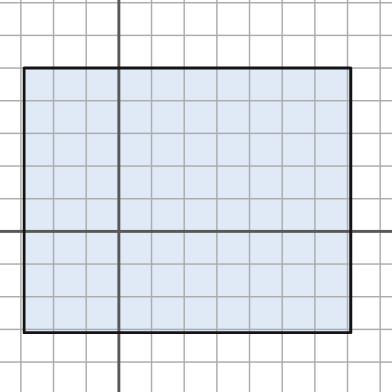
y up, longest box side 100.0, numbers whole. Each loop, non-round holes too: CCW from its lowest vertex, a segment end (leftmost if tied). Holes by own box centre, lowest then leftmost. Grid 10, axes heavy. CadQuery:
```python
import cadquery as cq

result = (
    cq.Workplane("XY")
    .moveTo(-29.0, -31.0)
    .lineTo(71.0, -31.0)
    .lineTo(71.0, 50.0)
    .lineTo(-29.0, 50.0)
    .close()
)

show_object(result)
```